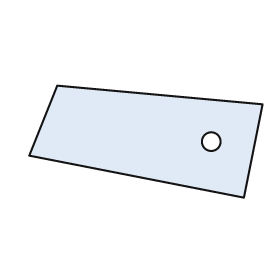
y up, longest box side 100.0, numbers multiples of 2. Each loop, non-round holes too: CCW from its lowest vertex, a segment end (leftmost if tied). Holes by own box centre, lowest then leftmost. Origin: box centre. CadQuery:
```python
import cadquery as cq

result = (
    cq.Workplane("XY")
    .moveTo(42.0, -24.0)
    .lineTo(50.0, 16.0)
    .lineTo(-38.0, 24.0)
    .lineTo(-50.0, -6.0)
    .close()
    .moveTo(28.0, 0.0)
    .circle(4.0)
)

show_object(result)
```